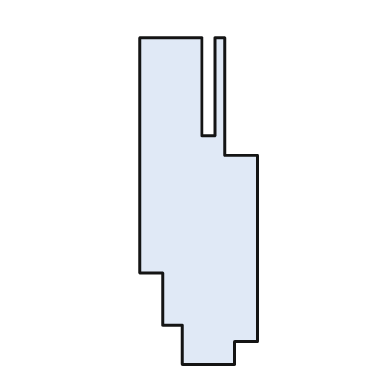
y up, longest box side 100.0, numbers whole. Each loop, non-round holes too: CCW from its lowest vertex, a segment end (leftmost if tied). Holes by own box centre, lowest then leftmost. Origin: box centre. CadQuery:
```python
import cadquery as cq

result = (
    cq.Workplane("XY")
    .moveTo(-5.0, -50.0)
    .lineTo(11.0, -50.0)
    .lineTo(11.0, -43.0)
    .lineTo(18.0, -43.0)
    .lineTo(18.0, 14.0)
    .lineTo(8.0, 14.0)
    .lineTo(8.0, 50.0)
    .lineTo(5.0, 50.0)
    .lineTo(5.0, 20.0)
    .lineTo(1.0, 20.0)
    .lineTo(1.0, 50.0)
    .lineTo(-18.0, 50.0)
    .lineTo(-18.0, -22.0)
    .lineTo(-11.0, -22.0)
    .lineTo(-11.0, -38.0)
    .lineTo(-5.0, -38.0)
    .close()
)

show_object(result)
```